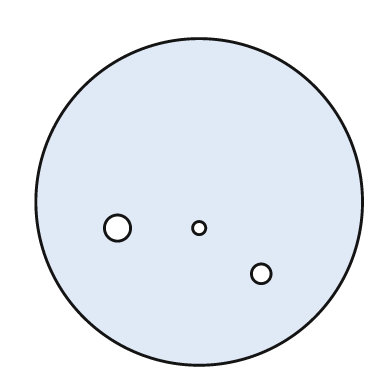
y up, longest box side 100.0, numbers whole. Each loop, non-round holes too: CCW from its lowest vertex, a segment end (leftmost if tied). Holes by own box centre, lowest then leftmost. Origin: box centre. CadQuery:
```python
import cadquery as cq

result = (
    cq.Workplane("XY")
    .moveTo(0.0, 0.0)
    .circle(50.0)
    .moveTo(19.0, -22.0)
    .circle(3.0)
    .moveTo(-25.0, -8.0)
    .circle(4.0)
    .moveTo(0.0, -8.0)
    .circle(2.0)
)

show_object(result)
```